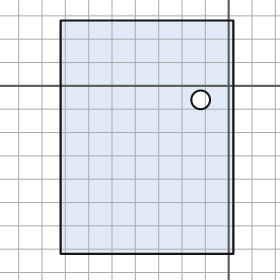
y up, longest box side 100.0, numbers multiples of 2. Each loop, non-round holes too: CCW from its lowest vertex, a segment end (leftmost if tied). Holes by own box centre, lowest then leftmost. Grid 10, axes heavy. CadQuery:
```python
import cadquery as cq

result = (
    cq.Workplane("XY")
    .moveTo(-72.0, -72.0)
    .lineTo(2.0, -72.0)
    .lineTo(2.0, 28.0)
    .lineTo(-72.0, 28.0)
    .close()
    .moveTo(-12.0, -6.0)
    .circle(4.0)
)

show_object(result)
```